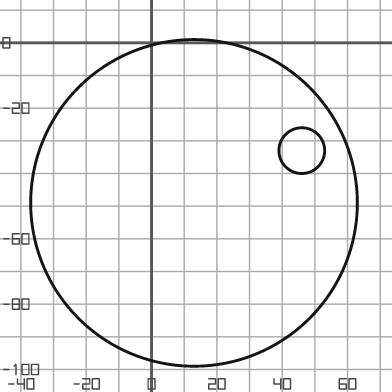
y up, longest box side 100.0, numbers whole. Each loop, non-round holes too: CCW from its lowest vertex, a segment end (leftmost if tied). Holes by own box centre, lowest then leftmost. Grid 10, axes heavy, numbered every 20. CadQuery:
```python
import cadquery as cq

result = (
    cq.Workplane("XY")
    .moveTo(13.0, -49.0)
    .circle(50.0)
    .moveTo(46.0, -33.0)
    .circle(7.0)
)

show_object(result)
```